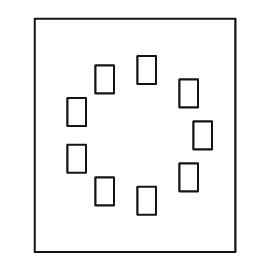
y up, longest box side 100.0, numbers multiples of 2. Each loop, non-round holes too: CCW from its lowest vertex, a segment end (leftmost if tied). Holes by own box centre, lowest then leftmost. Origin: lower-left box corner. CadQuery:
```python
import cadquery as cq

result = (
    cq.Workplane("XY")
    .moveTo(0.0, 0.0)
    .lineTo(86.0, 0.0)
    .lineTo(86.0, 100.0)
    .lineTo(0.0, 100.0)
    .close()
    .moveTo(44.0, 16.0)
    .lineTo(52.0, 16.0)
    .lineTo(52.0, 28.0)
    .lineTo(44.0, 28.0)
    .close()
    .moveTo(26.0, 20.0)
    .lineTo(34.0, 20.0)
    .lineTo(34.0, 32.0)
    .lineTo(26.0, 32.0)
    .close()
    .moveTo(62.0, 26.0)
    .lineTo(70.0, 26.0)
    .lineTo(70.0, 38.0)
    .lineTo(62.0, 38.0)
    .close()
    .moveTo(14.0, 34.0)
    .lineTo(22.0, 34.0)
    .lineTo(22.0, 46.0)
    .lineTo(14.0, 46.0)
    .close()
    .moveTo(68.0, 44.0)
    .lineTo(76.0, 44.0)
    .lineTo(76.0, 56.0)
    .lineTo(68.0, 56.0)
    .close()
    .moveTo(14.0, 54.0)
    .lineTo(22.0, 54.0)
    .lineTo(22.0, 66.0)
    .lineTo(14.0, 66.0)
    .close()
    .moveTo(62.0, 62.0)
    .lineTo(70.0, 62.0)
    .lineTo(70.0, 74.0)
    .lineTo(62.0, 74.0)
    .close()
    .moveTo(26.0, 68.0)
    .lineTo(34.0, 68.0)
    .lineTo(34.0, 80.0)
    .lineTo(26.0, 80.0)
    .close()
    .moveTo(44.0, 72.0)
    .lineTo(52.0, 72.0)
    .lineTo(52.0, 84.0)
    .lineTo(44.0, 84.0)
    .close()
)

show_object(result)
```